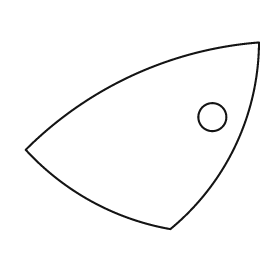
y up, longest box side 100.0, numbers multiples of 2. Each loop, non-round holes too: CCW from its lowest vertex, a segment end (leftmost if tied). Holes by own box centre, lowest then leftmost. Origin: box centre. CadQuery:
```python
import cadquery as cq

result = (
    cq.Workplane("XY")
    .moveTo(12.0, -40.0)
    .threePointArc((40.0, -4.0), (50.0, 40.0))
    .threePointArc((-4.0, 26.0), (-50.0, -6.0))
    .threePointArc((-22.0, -28.0), (12.0, -40.0))
    .close()
    .moveTo(30.0, 8.0)
    .circle(6.0)
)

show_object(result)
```